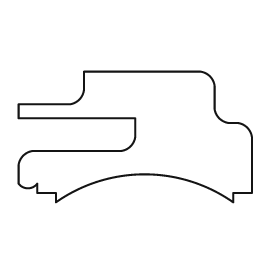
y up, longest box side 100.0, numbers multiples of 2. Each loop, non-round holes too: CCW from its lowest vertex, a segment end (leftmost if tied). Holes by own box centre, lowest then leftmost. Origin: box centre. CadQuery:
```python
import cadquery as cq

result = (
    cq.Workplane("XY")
    .moveTo(-34.0, -28.0)
    .threePointArc((4.0, -16.0), (42.0, -28.0))
    .lineTo(42.0, -24.0)
    .lineTo(50.0, -24.0)
    .lineTo(50.0, 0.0)
    .threePointArc((48.0, 4.0), (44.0, 6.0))
    .lineTo(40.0, 6.0)
    .threePointArc((36.0, 8.0), (34.0, 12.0))
    .lineTo(34.0, 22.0)
    .threePointArc((32.0, 26.0), (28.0, 28.0))
    .lineTo(-22.0, 28.0)
    .lineTo(-22.0, 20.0)
    .threePointArc((-24.0, 16.0), (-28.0, 14.0))
    .lineTo(-50.0, 14.0)
    .lineTo(-50.0, 8.0)
    .lineTo(0.0, 8.0)
    .lineTo(0.0, 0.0)
    .threePointArc((-2.0, -4.0), (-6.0, -6.0))
    .lineTo(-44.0, -6.0)
    .threePointArc((-48.0, -8.0), (-50.0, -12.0))
    .lineTo(-50.0, -20.0)
    .threePointArc((-46.0, -22.0), (-42.0, -20.0))
    .lineTo(-42.0, -24.0)
    .lineTo(-34.0, -24.0)
    .close()
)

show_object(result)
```